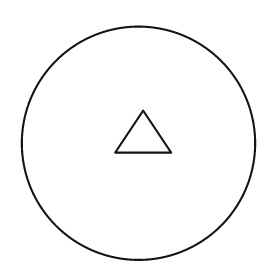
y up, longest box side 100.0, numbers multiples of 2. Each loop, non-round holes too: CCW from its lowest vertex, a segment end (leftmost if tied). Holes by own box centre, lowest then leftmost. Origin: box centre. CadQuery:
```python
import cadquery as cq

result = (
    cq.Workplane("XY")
    .moveTo(0.0, 0.0)
    .circle(50.0)
    .moveTo(-10.0, -4.0)
    .lineTo(14.0, -4.0)
    .lineTo(2.0, 14.0)
    .close()
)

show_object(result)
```